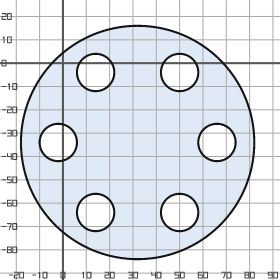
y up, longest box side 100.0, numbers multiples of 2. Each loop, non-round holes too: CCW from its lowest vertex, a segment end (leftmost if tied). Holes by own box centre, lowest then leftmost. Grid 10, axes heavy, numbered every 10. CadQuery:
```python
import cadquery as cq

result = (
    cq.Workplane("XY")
    .moveTo(32.0, -34.0)
    .circle(50.0)
    .moveTo(14.0, -64.0)
    .circle(8.0)
    .moveTo(50.0, -64.0)
    .circle(8.0)
    .moveTo(-2.0, -34.0)
    .circle(8.0)
    .moveTo(66.0, -34.0)
    .circle(8.0)
    .moveTo(14.0, -4.0)
    .circle(8.0)
    .moveTo(50.0, -4.0)
    .circle(8.0)
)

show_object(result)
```